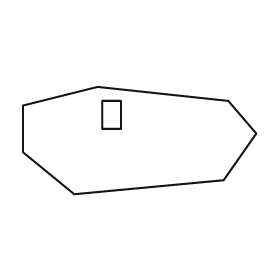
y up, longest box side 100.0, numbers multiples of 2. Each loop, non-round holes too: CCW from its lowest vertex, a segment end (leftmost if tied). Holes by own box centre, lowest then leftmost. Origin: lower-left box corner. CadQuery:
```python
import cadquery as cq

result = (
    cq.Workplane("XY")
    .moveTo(22.0, 0.0)
    .lineTo(86.0, 6.0)
    .lineTo(100.0, 26.0)
    .lineTo(88.0, 40.0)
    .lineTo(32.0, 46.0)
    .lineTo(0.0, 38.0)
    .lineTo(0.0, 18.0)
    .close()
    .moveTo(34.0, 28.0)
    .lineTo(42.0, 28.0)
    .lineTo(42.0, 40.0)
    .lineTo(34.0, 40.0)
    .close()
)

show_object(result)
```